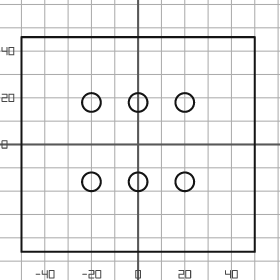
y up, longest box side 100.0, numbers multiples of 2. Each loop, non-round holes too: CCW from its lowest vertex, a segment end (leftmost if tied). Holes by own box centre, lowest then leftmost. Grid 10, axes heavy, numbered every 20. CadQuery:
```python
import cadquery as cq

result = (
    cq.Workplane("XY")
    .moveTo(-50.0, -46.0)
    .lineTo(50.0, -46.0)
    .lineTo(50.0, 46.0)
    .lineTo(-50.0, 46.0)
    .close()
    .moveTo(-20.0, -16.0)
    .circle(4.0)
    .moveTo(0.0, -16.0)
    .circle(4.0)
    .moveTo(20.0, -16.0)
    .circle(4.0)
    .moveTo(-20.0, 18.0)
    .circle(4.0)
    .moveTo(0.0, 18.0)
    .circle(4.0)
    .moveTo(20.0, 18.0)
    .circle(4.0)
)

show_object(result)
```